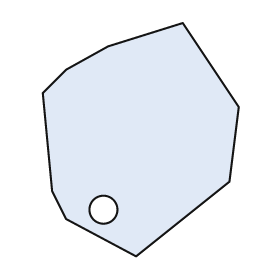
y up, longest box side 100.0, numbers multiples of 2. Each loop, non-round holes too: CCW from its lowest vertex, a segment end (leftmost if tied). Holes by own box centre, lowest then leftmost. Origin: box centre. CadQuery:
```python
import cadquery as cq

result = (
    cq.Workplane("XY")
    .moveTo(-2.0, -50.0)
    .lineTo(38.0, -18.0)
    .lineTo(42.0, 14.0)
    .lineTo(18.0, 50.0)
    .lineTo(-14.0, 40.0)
    .lineTo(-32.0, 30.0)
    .lineTo(-42.0, 20.0)
    .lineTo(-38.0, -22.0)
    .lineTo(-32.0, -34.0)
    .close()
    .moveTo(-16.0, -30.0)
    .circle(6.0)
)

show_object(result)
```